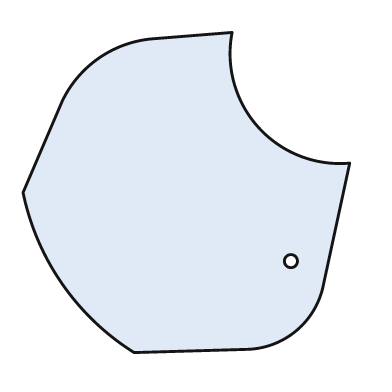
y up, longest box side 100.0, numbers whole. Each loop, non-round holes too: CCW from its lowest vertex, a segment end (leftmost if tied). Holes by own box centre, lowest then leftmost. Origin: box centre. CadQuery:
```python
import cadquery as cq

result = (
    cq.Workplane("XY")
    .moveTo(-16.0, -49.0)
    .lineTo(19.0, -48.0)
    .threePointArc((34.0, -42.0), (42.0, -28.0))
    .lineTo(50.0, 9.0)
    .threePointArc((22.0, 20.0), (14.0, 49.0))
    .lineTo(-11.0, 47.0)
    .threePointArc((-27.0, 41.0), (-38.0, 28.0))
    .lineTo(-50.0, 0.0)
    .threePointArc((-38.0, -28.0), (-16.0, -49.0))
    .close()
    .moveTo(32.0, -21.0)
    .circle(2.0)
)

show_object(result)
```